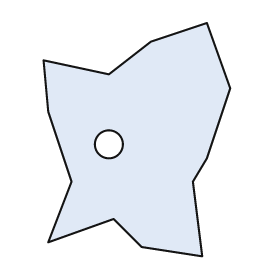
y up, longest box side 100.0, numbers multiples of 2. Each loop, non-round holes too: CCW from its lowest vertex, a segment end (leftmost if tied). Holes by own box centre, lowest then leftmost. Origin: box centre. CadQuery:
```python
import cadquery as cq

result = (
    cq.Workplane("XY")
    .moveTo(28.0, -50.0)
    .lineTo(24.0, -18.0)
    .lineTo(30.0, -8.0)
    .lineTo(40.0, 22.0)
    .lineTo(30.0, 50.0)
    .lineTo(6.0, 42.0)
    .lineTo(-12.0, 28.0)
    .lineTo(-40.0, 34.0)
    .lineTo(-38.0, 12.0)
    .lineTo(-28.0, -18.0)
    .lineTo(-38.0, -44.0)
    .lineTo(-10.0, -34.0)
    .lineTo(2.0, -46.0)
    .close()
    .moveTo(-12.0, -2.0)
    .circle(6.0)
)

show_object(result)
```